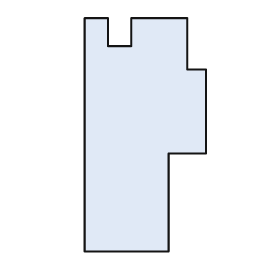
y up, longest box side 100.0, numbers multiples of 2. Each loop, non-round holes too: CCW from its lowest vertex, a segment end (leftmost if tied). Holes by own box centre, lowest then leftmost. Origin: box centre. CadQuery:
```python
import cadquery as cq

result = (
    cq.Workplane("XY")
    .moveTo(-26.0, -50.0)
    .lineTo(10.0, -50.0)
    .lineTo(10.0, -8.0)
    .lineTo(26.0, -8.0)
    .lineTo(26.0, 28.0)
    .lineTo(18.0, 28.0)
    .lineTo(18.0, 50.0)
    .lineTo(-6.0, 50.0)
    .lineTo(-6.0, 38.0)
    .lineTo(-16.0, 38.0)
    .lineTo(-16.0, 50.0)
    .lineTo(-26.0, 50.0)
    .close()
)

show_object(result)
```